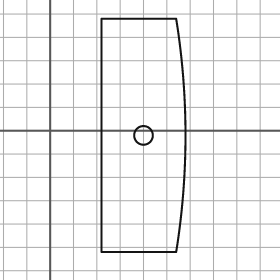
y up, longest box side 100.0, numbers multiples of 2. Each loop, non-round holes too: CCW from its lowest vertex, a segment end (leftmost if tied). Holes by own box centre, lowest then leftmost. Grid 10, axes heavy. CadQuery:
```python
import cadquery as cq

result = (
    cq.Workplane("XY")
    .moveTo(22.0, -52.0)
    .lineTo(54.0, -52.0)
    .threePointArc((58.0, -2.0), (54.0, 48.0))
    .lineTo(22.0, 48.0)
    .close()
    .moveTo(40.0, -2.0)
    .circle(4.0)
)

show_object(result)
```